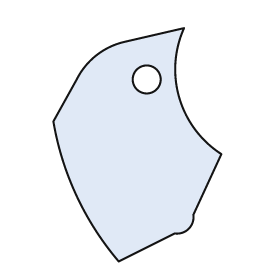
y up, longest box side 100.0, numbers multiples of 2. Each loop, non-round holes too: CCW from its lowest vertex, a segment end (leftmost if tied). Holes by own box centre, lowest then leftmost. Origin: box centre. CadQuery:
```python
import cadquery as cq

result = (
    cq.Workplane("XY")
    .moveTo(-8.0, -50.0)
    .lineTo(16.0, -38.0)
    .threePointArc((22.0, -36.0), (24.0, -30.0))
    .lineTo(36.0, -4.0)
    .threePointArc((18.0, 20.0), (20.0, 50.0))
    .lineTo(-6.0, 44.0)
    .threePointArc((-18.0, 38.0), (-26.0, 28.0))
    .lineTo(-36.0, 10.0)
    .threePointArc((-26.0, -22.0), (-8.0, -50.0))
    .close()
    .moveTo(4.0, 28.0)
    .circle(6.0)
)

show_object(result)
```